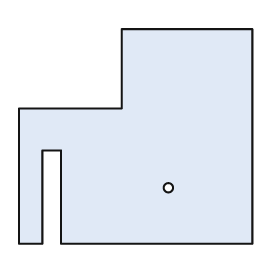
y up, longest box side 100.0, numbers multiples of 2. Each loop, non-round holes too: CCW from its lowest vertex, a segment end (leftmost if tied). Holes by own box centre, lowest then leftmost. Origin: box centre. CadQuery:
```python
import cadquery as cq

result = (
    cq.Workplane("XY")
    .moveTo(-50.0, -46.0)
    .lineTo(-40.0, -46.0)
    .lineTo(-40.0, -6.0)
    .lineTo(-32.0, -6.0)
    .lineTo(-32.0, -46.0)
    .lineTo(50.0, -46.0)
    .lineTo(50.0, 46.0)
    .lineTo(-6.0, 46.0)
    .lineTo(-6.0, 12.0)
    .lineTo(-50.0, 12.0)
    .close()
    .moveTo(14.0, -22.0)
    .circle(2.0)
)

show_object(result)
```